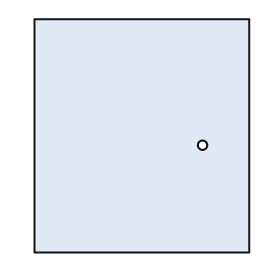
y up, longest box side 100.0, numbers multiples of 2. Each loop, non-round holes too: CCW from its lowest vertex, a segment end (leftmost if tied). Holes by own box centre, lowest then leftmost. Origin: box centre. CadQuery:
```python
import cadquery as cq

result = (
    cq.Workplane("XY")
    .moveTo(-46.0, -50.0)
    .lineTo(46.0, -50.0)
    .lineTo(46.0, 50.0)
    .lineTo(-46.0, 50.0)
    .close()
    .moveTo(26.0, -4.0)
    .circle(2.0)
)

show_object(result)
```